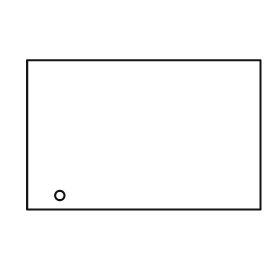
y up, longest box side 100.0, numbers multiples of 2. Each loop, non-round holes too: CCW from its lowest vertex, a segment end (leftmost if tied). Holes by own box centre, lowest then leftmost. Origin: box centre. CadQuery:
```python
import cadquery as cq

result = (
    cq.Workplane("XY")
    .moveTo(-50.0, -32.0)
    .lineTo(50.0, -32.0)
    .lineTo(50.0, 32.0)
    .lineTo(-50.0, 32.0)
    .close()
    .moveTo(-36.0, -26.0)
    .circle(2.0)
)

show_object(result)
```